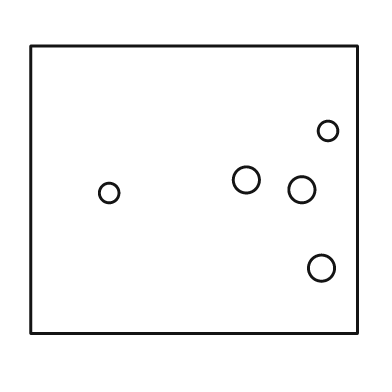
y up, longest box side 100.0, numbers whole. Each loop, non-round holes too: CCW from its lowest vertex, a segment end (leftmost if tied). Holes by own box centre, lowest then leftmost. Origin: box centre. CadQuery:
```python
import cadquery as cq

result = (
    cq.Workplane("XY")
    .moveTo(-50.0, -44.0)
    .lineTo(50.0, -44.0)
    .lineTo(50.0, 44.0)
    .lineTo(-50.0, 44.0)
    .close()
    .moveTo(39.0, -24.0)
    .circle(4.0)
    .moveTo(-26.0, -1.0)
    .circle(3.0)
    .moveTo(33.0, 0.0)
    .circle(4.0)
    .moveTo(16.0, 3.0)
    .circle(4.0)
    .moveTo(41.0, 18.0)
    .circle(3.0)
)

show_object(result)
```